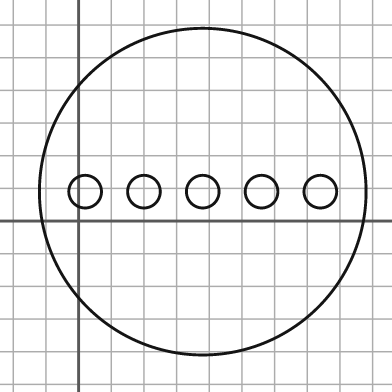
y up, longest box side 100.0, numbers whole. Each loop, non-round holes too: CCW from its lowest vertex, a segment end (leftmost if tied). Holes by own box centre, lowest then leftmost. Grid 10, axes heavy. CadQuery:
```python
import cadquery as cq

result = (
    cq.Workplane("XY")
    .moveTo(38.0, 9.0)
    .circle(50.0)
    .moveTo(2.0, 9.0)
    .circle(5.0)
    .moveTo(20.0, 9.0)
    .circle(5.0)
    .moveTo(38.0, 9.0)
    .circle(5.0)
    .moveTo(56.0, 9.0)
    .circle(5.0)
    .moveTo(74.0, 9.0)
    .circle(5.0)
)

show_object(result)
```